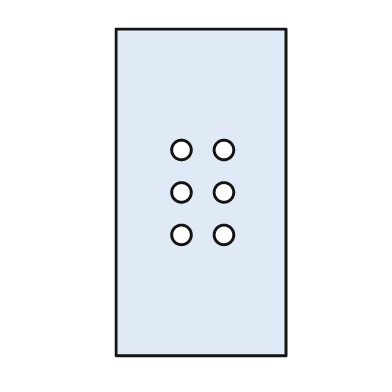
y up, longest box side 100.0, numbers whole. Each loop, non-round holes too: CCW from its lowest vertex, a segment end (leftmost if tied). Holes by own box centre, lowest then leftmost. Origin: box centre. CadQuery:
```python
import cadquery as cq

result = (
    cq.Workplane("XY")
    .moveTo(-26.0, -50.0)
    .lineTo(26.0, -50.0)
    .lineTo(26.0, 50.0)
    .lineTo(-26.0, 50.0)
    .close()
    .moveTo(-6.0, -13.0)
    .circle(3.0)
    .moveTo(7.0, -13.0)
    .circle(3.0)
    .moveTo(-6.0, 0.0)
    .circle(3.0)
    .moveTo(7.0, 0.0)
    .circle(3.0)
    .moveTo(-6.0, 13.0)
    .circle(3.0)
    .moveTo(7.0, 13.0)
    .circle(3.0)
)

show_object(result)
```